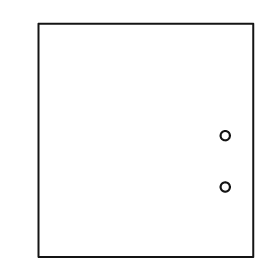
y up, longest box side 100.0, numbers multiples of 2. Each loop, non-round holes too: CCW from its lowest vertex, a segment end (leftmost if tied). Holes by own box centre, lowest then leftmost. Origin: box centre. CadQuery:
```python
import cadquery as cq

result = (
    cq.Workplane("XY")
    .moveTo(-46.0, -50.0)
    .lineTo(46.0, -50.0)
    .lineTo(46.0, 50.0)
    .lineTo(-46.0, 50.0)
    .close()
    .moveTo(34.0, -20.0)
    .circle(2.0)
    .moveTo(34.0, 2.0)
    .circle(2.0)
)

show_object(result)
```